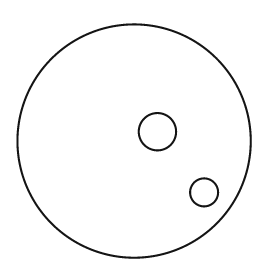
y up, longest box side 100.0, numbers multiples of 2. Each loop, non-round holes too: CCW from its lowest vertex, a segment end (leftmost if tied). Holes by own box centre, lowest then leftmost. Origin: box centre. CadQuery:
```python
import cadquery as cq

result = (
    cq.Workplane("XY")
    .moveTo(0.0, 0.0)
    .circle(50.0)
    .moveTo(30.0, -22.0)
    .circle(6.0)
    .moveTo(10.0, 4.0)
    .circle(8.0)
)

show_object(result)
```